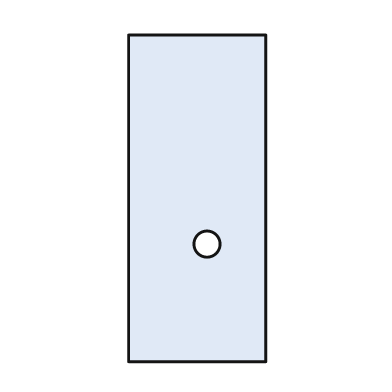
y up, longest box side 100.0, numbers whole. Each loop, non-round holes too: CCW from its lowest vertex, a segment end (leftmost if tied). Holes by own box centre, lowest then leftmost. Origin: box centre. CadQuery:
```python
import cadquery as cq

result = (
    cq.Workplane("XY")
    .moveTo(-21.0, -50.0)
    .lineTo(21.0, -50.0)
    .lineTo(21.0, 50.0)
    .lineTo(-21.0, 50.0)
    .close()
    .moveTo(3.0, -14.0)
    .circle(4.0)
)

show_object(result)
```